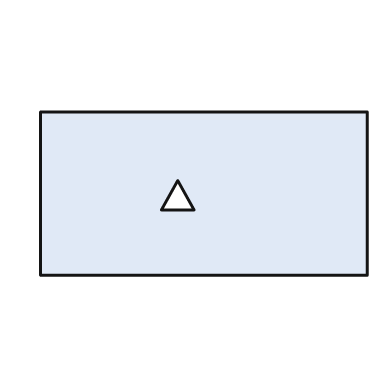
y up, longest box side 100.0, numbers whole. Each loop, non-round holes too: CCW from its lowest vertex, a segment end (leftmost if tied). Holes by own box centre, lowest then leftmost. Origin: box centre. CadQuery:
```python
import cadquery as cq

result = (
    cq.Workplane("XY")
    .moveTo(-50.0, -25.0)
    .lineTo(50.0, -25.0)
    .lineTo(50.0, 25.0)
    .lineTo(-50.0, 25.0)
    .close()
    .moveTo(-13.0, -5.0)
    .lineTo(-3.0, -5.0)
    .lineTo(-8.0, 4.0)
    .close()
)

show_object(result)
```